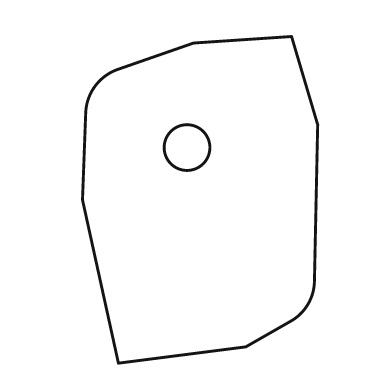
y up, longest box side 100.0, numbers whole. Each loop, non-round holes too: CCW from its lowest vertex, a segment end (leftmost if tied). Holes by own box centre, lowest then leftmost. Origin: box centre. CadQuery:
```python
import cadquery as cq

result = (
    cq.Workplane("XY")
    .moveTo(-25.0, -50.0)
    .lineTo(14.0, -45.0)
    .lineTo(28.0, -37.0)
    .threePointArc((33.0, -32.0), (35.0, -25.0))
    .lineTo(36.0, 23.0)
    .lineTo(28.0, 50.0)
    .lineTo(-2.0, 48.0)
    .lineTo(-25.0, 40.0)
    .threePointArc((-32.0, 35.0), (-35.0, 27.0))
    .lineTo(-36.0, 0.0)
    .close()
    .moveTo(-4.0, 16.0)
    .circle(7.0)
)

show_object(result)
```